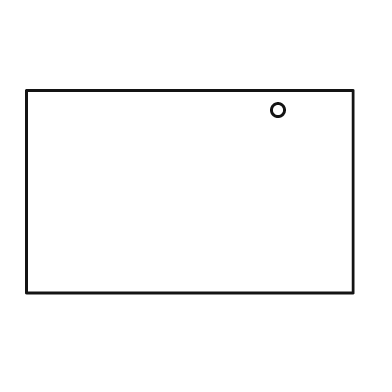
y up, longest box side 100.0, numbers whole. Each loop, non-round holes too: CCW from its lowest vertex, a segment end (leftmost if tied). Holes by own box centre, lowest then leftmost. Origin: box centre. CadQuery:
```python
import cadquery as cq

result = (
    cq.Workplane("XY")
    .moveTo(-50.0, -31.0)
    .lineTo(50.0, -31.0)
    .lineTo(50.0, 31.0)
    .lineTo(-50.0, 31.0)
    .close()
    .moveTo(27.0, 25.0)
    .circle(2.0)
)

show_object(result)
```